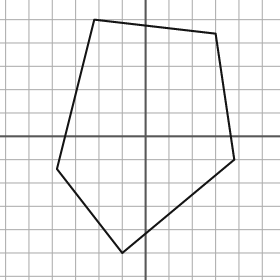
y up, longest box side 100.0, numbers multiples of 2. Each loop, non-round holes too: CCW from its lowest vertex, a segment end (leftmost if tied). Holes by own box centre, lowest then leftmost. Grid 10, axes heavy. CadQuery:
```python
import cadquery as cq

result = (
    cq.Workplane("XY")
    .moveTo(-10.0, -50.0)
    .lineTo(38.0, -10.0)
    .lineTo(30.0, 44.0)
    .lineTo(-22.0, 50.0)
    .lineTo(-38.0, -14.0)
    .close()
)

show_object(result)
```